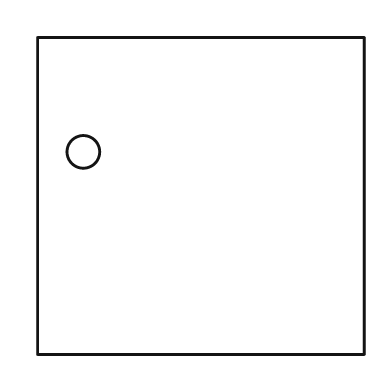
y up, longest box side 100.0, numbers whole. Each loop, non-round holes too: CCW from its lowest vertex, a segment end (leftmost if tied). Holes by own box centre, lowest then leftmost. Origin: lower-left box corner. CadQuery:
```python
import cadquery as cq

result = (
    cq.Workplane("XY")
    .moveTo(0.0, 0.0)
    .lineTo(100.0, 0.0)
    .lineTo(100.0, 97.0)
    .lineTo(0.0, 97.0)
    .close()
    .moveTo(14.0, 62.0)
    .circle(5.0)
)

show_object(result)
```